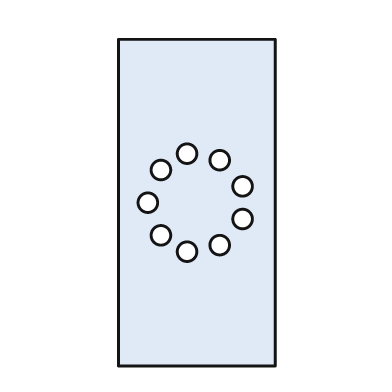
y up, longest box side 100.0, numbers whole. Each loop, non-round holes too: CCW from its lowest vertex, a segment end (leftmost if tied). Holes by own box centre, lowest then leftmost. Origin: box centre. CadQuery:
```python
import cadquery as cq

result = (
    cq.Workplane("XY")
    .moveTo(-24.0, -50.0)
    .lineTo(24.0, -50.0)
    .lineTo(24.0, 50.0)
    .lineTo(-24.0, 50.0)
    .close()
    .moveTo(-3.0, -15.0)
    .circle(3.0)
    .moveTo(7.0, -13.0)
    .circle(3.0)
    .moveTo(-11.0, -10.0)
    .circle(3.0)
    .moveTo(14.0, -5.0)
    .circle(3.0)
    .moveTo(-15.0, 0.0)
    .circle(3.0)
    .moveTo(14.0, 5.0)
    .circle(3.0)
    .moveTo(-11.0, 10.0)
    .circle(3.0)
    .moveTo(7.0, 13.0)
    .circle(3.0)
    .moveTo(-3.0, 15.0)
    .circle(3.0)
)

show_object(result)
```